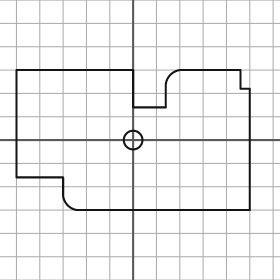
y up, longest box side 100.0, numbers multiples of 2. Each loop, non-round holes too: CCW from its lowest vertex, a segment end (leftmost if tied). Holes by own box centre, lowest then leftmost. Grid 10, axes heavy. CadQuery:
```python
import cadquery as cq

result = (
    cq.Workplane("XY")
    .moveTo(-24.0, -30.0)
    .lineTo(50.0, -30.0)
    .lineTo(50.0, 22.0)
    .lineTo(46.0, 22.0)
    .lineTo(46.0, 30.0)
    .lineTo(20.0, 30.0)
    .threePointArc((16.0, 28.0), (14.0, 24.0))
    .lineTo(14.0, 14.0)
    .lineTo(0.0, 14.0)
    .lineTo(0.0, 30.0)
    .lineTo(-50.0, 30.0)
    .lineTo(-50.0, -16.0)
    .lineTo(-30.0, -16.0)
    .lineTo(-30.0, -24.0)
    .threePointArc((-28.0, -28.0), (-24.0, -30.0))
    .close()
    .moveTo(0.0, 0.0)
    .circle(4.0)
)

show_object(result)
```